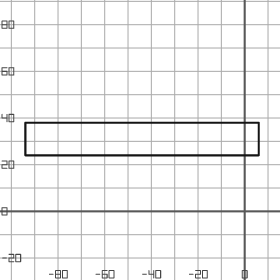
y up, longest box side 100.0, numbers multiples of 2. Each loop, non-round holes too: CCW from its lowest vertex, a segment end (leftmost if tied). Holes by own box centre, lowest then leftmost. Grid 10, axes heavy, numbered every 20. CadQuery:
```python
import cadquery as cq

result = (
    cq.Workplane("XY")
    .moveTo(-94.0, 24.0)
    .lineTo(6.0, 24.0)
    .lineTo(6.0, 38.0)
    .lineTo(-94.0, 38.0)
    .close()
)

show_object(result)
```